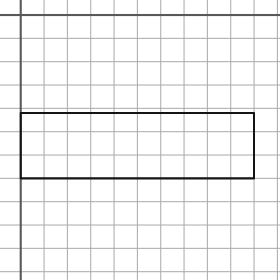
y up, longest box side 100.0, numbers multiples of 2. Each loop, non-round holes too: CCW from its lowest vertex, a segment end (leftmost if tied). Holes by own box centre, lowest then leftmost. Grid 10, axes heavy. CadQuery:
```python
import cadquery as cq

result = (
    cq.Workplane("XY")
    .moveTo(0.0, -70.0)
    .lineTo(100.0, -70.0)
    .lineTo(100.0, -42.0)
    .lineTo(0.0, -42.0)
    .close()
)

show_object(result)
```